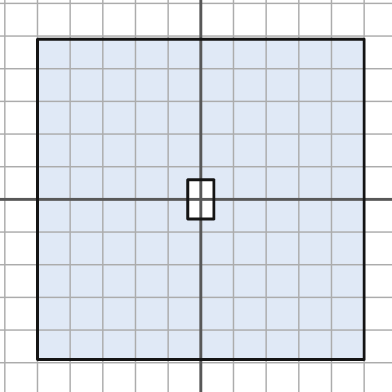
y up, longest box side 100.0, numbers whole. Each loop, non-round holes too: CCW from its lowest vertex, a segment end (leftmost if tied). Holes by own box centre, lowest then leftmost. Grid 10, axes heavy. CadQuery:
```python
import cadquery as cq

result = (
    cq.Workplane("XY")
    .moveTo(-50.0, -49.0)
    .lineTo(50.0, -49.0)
    .lineTo(50.0, 49.0)
    .lineTo(-50.0, 49.0)
    .close()
    .moveTo(-4.0, -6.0)
    .lineTo(4.0, -6.0)
    .lineTo(4.0, 6.0)
    .lineTo(-4.0, 6.0)
    .close()
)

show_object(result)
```